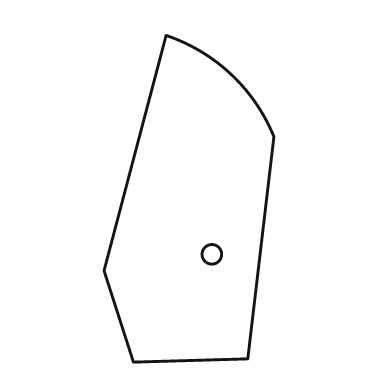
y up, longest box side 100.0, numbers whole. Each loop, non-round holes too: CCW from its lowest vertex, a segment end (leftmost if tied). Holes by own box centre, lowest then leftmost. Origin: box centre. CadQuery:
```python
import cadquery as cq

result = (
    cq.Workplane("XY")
    .moveTo(-17.0, -50.0)
    .lineTo(18.0, -49.0)
    .lineTo(26.0, 19.0)
    .threePointArc((13.0, 38.0), (-7.0, 50.0))
    .lineTo(-26.0, -22.0)
    .close()
    .moveTo(7.0, -17.0)
    .circle(3.0)
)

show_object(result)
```